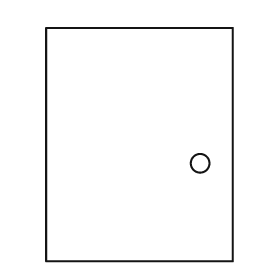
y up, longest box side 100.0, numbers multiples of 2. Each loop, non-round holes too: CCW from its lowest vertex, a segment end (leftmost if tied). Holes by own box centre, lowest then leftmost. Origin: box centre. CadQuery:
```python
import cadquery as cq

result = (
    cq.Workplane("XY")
    .moveTo(-40.0, -50.0)
    .lineTo(40.0, -50.0)
    .lineTo(40.0, 50.0)
    .lineTo(-40.0, 50.0)
    .close()
    .moveTo(26.0, -8.0)
    .circle(4.0)
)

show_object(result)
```